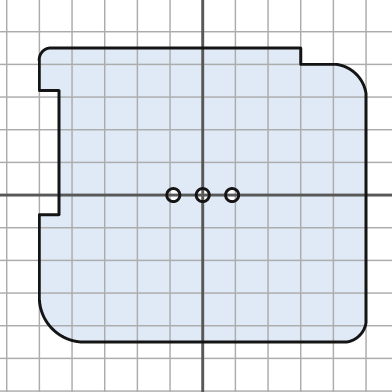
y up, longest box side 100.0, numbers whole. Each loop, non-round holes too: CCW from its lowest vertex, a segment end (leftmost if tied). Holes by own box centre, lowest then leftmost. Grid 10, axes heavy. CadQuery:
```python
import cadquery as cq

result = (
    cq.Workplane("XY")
    .moveTo(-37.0, -45.0)
    .lineTo(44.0, -45.0)
    .threePointArc((48.0, -43.0), (50.0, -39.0))
    .lineTo(50.0, 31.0)
    .threePointArc((47.0, 37.0), (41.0, 40.0))
    .lineTo(30.0, 40.0)
    .lineTo(30.0, 45.0)
    .lineTo(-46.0, 45.0)
    .threePointArc((-49.0, 44.0), (-50.0, 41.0))
    .lineTo(-50.0, 32.0)
    .lineTo(-44.0, 32.0)
    .lineTo(-44.0, -6.0)
    .lineTo(-50.0, -6.0)
    .lineTo(-50.0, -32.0)
    .threePointArc((-46.0, -41.0), (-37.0, -45.0))
    .close()
    .moveTo(-9.0, 0.0)
    .circle(2.0)
    .moveTo(0.0, 0.0)
    .circle(2.0)
    .moveTo(9.0, 0.0)
    .circle(2.0)
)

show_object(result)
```